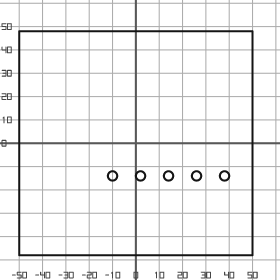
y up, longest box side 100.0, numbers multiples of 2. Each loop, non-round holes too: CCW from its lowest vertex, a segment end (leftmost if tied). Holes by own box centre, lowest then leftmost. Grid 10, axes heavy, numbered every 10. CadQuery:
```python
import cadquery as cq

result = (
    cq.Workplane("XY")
    .moveTo(-50.0, -48.0)
    .lineTo(50.0, -48.0)
    .lineTo(50.0, 48.0)
    .lineTo(-50.0, 48.0)
    .close()
    .moveTo(-10.0, -14.0)
    .circle(2.0)
    .moveTo(2.0, -14.0)
    .circle(2.0)
    .moveTo(14.0, -14.0)
    .circle(2.0)
    .moveTo(26.0, -14.0)
    .circle(2.0)
    .moveTo(38.0, -14.0)
    .circle(2.0)
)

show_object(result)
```